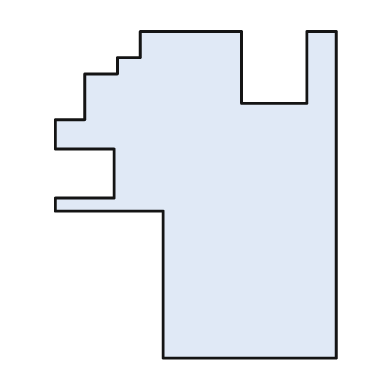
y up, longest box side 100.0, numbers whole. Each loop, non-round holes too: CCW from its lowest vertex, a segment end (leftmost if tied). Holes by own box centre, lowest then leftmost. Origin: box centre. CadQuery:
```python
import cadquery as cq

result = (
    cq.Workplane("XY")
    .moveTo(-10.0, -50.0)
    .lineTo(43.0, -50.0)
    .lineTo(43.0, 50.0)
    .lineTo(34.0, 50.0)
    .lineTo(34.0, 28.0)
    .lineTo(14.0, 28.0)
    .lineTo(14.0, 50.0)
    .lineTo(-17.0, 50.0)
    .lineTo(-17.0, 42.0)
    .lineTo(-24.0, 42.0)
    .lineTo(-24.0, 37.0)
    .lineTo(-34.0, 37.0)
    .lineTo(-34.0, 23.0)
    .lineTo(-43.0, 23.0)
    .lineTo(-43.0, 14.0)
    .lineTo(-25.0, 14.0)
    .lineTo(-25.0, -1.0)
    .lineTo(-43.0, -1.0)
    .lineTo(-43.0, -5.0)
    .lineTo(-10.0, -5.0)
    .close()
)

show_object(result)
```